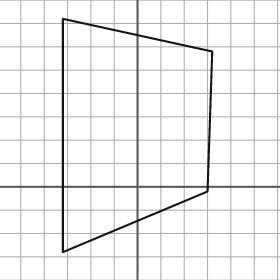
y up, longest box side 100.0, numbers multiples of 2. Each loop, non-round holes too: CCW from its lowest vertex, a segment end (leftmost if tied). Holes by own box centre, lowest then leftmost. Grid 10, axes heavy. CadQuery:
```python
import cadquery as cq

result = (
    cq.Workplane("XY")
    .moveTo(-32.0, -28.0)
    .lineTo(30.0, -2.0)
    .lineTo(32.0, 58.0)
    .lineTo(-32.0, 72.0)
    .close()
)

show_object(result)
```